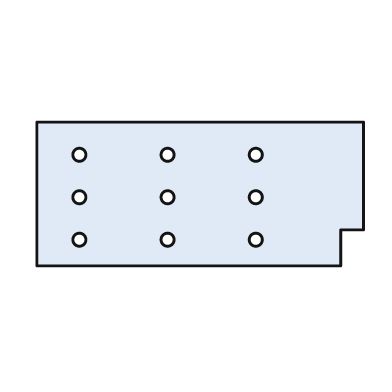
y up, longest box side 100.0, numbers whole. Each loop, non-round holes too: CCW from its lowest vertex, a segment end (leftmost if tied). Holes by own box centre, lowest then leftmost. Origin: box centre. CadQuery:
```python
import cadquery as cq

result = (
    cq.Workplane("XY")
    .moveTo(-50.0, -22.0)
    .lineTo(43.0, -22.0)
    .lineTo(43.0, -11.0)
    .lineTo(50.0, -11.0)
    .lineTo(50.0, 22.0)
    .lineTo(-50.0, 22.0)
    .close()
    .moveTo(-37.0, -14.0)
    .circle(2.0)
    .moveTo(-10.0, -14.0)
    .circle(2.0)
    .moveTo(17.0, -14.0)
    .circle(2.0)
    .moveTo(-37.0, -1.0)
    .circle(2.0)
    .moveTo(-10.0, -1.0)
    .circle(2.0)
    .moveTo(17.0, -1.0)
    .circle(2.0)
    .moveTo(-37.0, 12.0)
    .circle(2.0)
    .moveTo(-10.0, 12.0)
    .circle(2.0)
    .moveTo(17.0, 12.0)
    .circle(2.0)
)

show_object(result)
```